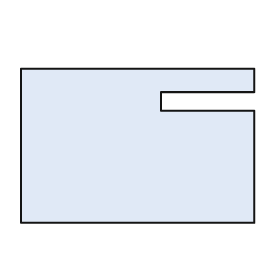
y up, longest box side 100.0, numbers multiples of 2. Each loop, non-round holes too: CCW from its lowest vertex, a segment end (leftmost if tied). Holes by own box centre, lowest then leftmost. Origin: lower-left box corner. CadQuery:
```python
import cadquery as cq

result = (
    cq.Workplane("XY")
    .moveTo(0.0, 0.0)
    .lineTo(100.0, 0.0)
    .lineTo(100.0, 48.0)
    .lineTo(60.0, 48.0)
    .lineTo(60.0, 56.0)
    .lineTo(100.0, 56.0)
    .lineTo(100.0, 66.0)
    .lineTo(0.0, 66.0)
    .close()
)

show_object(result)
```